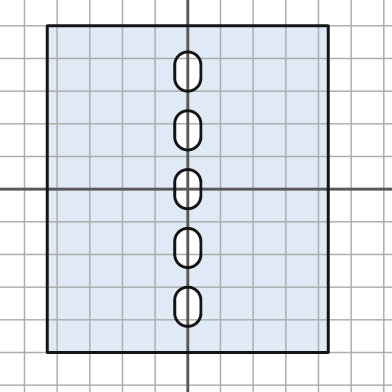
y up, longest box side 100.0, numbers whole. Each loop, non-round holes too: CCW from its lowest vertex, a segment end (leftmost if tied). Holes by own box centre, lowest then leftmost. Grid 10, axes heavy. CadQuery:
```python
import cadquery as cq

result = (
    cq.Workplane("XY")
    .moveTo(-43.0, -50.0)
    .lineTo(43.0, -50.0)
    .lineTo(43.0, 50.0)
    .lineTo(-43.0, 50.0)
    .close()
    .moveTo(-4.0, -38.0)
    .threePointArc((0.0, -42.0), (4.0, -38.0))
    .lineTo(4.0, -34.0)
    .threePointArc((0.0, -30.0), (-4.0, -34.0))
    .close()
    .moveTo(-4.0, -20.0)
    .threePointArc((0.0, -24.0), (4.0, -20.0))
    .lineTo(4.0, -16.0)
    .threePointArc((0.0, -12.0), (-4.0, -16.0))
    .close()
    .moveTo(-4.0, -2.0)
    .threePointArc((0.0, -6.0), (4.0, -2.0))
    .lineTo(4.0, 2.0)
    .threePointArc((0.0, 6.0), (-4.0, 2.0))
    .close()
    .moveTo(-4.0, 16.0)
    .threePointArc((0.0, 12.0), (4.0, 16.0))
    .lineTo(4.0, 20.0)
    .threePointArc((0.0, 24.0), (-4.0, 20.0))
    .close()
    .moveTo(-4.0, 34.0)
    .threePointArc((0.0, 30.0), (4.0, 34.0))
    .lineTo(4.0, 38.0)
    .threePointArc((0.0, 42.0), (-4.0, 38.0))
    .close()
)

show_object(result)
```